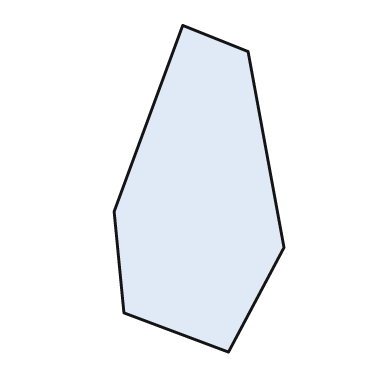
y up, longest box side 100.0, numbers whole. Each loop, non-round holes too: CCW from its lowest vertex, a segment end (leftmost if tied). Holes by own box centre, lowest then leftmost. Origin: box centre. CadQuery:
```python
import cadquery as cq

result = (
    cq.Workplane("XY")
    .moveTo(9.0, -50.0)
    .lineTo(26.0, -18.0)
    .lineTo(15.0, 42.0)
    .lineTo(-5.0, 50.0)
    .lineTo(-26.0, -7.0)
    .lineTo(-23.0, -38.0)
    .close()
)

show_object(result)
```